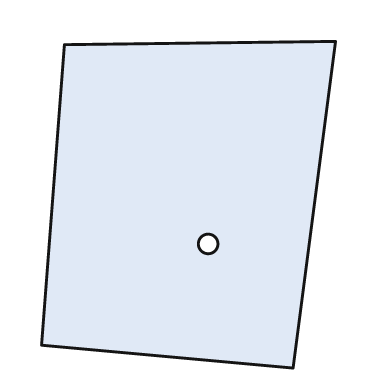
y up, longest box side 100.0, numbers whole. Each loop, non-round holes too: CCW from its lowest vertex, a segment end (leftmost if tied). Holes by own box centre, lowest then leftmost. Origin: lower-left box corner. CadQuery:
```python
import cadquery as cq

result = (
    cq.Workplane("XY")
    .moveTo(77.0, 0.0)
    .lineTo(90.0, 100.0)
    .lineTo(7.0, 99.0)
    .lineTo(0.0, 7.0)
    .close()
    .moveTo(51.0, 38.0)
    .circle(3.0)
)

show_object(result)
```